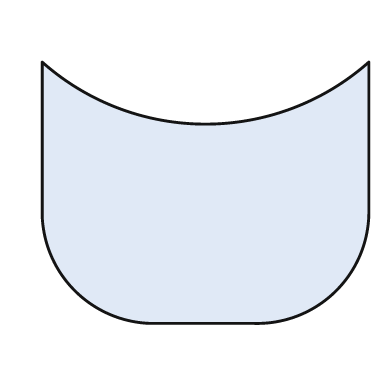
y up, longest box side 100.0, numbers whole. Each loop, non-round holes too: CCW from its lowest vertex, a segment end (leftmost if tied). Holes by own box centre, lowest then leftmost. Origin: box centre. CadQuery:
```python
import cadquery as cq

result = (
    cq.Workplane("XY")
    .moveTo(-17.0, -40.0)
    .lineTo(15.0, -40.0)
    .threePointArc((40.0, -30.0), (50.0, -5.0))
    .lineTo(50.0, 40.0)
    .threePointArc((0.0, 21.0), (-50.0, 40.0))
    .lineTo(-50.0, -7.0)
    .threePointArc((-40.0, -30.0), (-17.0, -40.0))
    .close()
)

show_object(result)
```